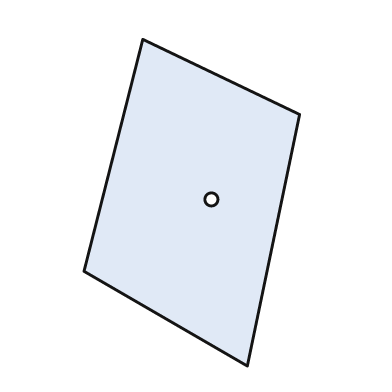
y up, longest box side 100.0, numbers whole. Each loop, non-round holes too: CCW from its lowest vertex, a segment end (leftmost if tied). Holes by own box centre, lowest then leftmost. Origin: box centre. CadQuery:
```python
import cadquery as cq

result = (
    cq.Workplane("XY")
    .moveTo(17.0, -50.0)
    .lineTo(33.0, 27.0)
    .lineTo(-15.0, 50.0)
    .lineTo(-33.0, -21.0)
    .close()
    .moveTo(6.0, 1.0)
    .circle(2.0)
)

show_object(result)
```